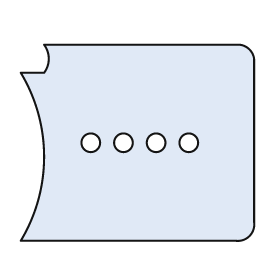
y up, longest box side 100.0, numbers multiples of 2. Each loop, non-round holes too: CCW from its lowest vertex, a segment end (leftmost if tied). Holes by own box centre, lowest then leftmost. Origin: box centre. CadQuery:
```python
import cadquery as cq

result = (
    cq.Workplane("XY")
    .moveTo(-50.0, -42.0)
    .lineTo(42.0, -42.0)
    .threePointArc((48.0, -40.0), (50.0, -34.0))
    .lineTo(50.0, 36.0)
    .threePointArc((48.0, 40.0), (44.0, 42.0))
    .lineTo(-40.0, 42.0)
    .threePointArc((-38.0, 36.0), (-40.0, 30.0))
    .lineTo(-50.0, 30.0)
    .threePointArc((-40.0, -6.0), (-50.0, -42.0))
    .close()
    .moveTo(-20.0, 0.0)
    .circle(4.0)
    .moveTo(-6.0, 0.0)
    .circle(4.0)
    .moveTo(8.0, 0.0)
    .circle(4.0)
    .moveTo(22.0, 0.0)
    .circle(4.0)
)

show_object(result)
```